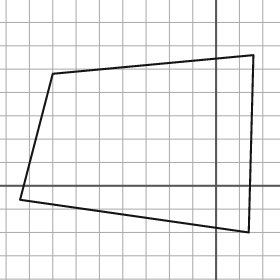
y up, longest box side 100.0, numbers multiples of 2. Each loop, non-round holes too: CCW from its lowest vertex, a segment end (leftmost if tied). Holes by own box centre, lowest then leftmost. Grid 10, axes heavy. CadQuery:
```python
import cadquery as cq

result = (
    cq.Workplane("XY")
    .moveTo(14.0, -20.0)
    .lineTo(16.0, 56.0)
    .lineTo(-70.0, 48.0)
    .lineTo(-84.0, -6.0)
    .close()
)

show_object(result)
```